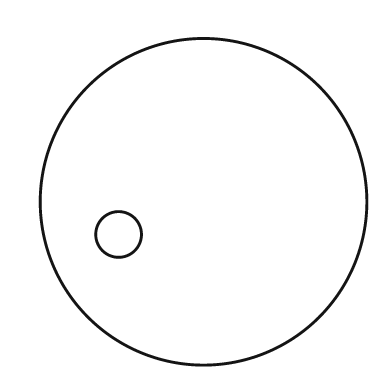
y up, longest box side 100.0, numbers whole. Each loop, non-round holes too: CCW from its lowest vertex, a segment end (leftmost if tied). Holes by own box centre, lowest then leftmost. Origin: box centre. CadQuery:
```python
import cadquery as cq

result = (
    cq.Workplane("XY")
    .moveTo(0.0, 0.0)
    .circle(50.0)
    .moveTo(-26.0, -10.0)
    .circle(7.0)
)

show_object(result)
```